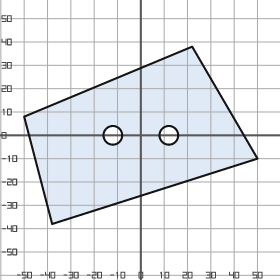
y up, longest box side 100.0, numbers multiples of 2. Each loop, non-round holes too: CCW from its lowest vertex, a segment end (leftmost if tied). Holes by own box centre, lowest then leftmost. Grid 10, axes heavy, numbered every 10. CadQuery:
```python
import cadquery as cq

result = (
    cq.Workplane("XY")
    .moveTo(-38.0, -38.0)
    .lineTo(50.0, -10.0)
    .lineTo(22.0, 38.0)
    .lineTo(-50.0, 8.0)
    .close()
    .moveTo(-12.0, 0.0)
    .circle(4.0)
    .moveTo(12.0, 0.0)
    .circle(4.0)
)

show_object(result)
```